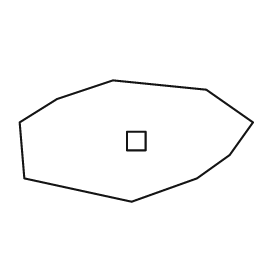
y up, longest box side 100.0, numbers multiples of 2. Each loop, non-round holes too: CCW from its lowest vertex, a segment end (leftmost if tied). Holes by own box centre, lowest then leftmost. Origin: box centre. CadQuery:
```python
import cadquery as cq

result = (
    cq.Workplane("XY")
    .moveTo(-2.0, -26.0)
    .lineTo(26.0, -16.0)
    .lineTo(40.0, -6.0)
    .lineTo(50.0, 8.0)
    .lineTo(30.0, 22.0)
    .lineTo(-10.0, 26.0)
    .lineTo(-34.0, 18.0)
    .lineTo(-50.0, 8.0)
    .lineTo(-48.0, -16.0)
    .close()
    .moveTo(-4.0, -4.0)
    .lineTo(4.0, -4.0)
    .lineTo(4.0, 4.0)
    .lineTo(-4.0, 4.0)
    .close()
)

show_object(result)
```